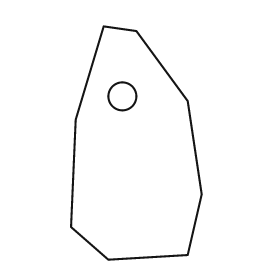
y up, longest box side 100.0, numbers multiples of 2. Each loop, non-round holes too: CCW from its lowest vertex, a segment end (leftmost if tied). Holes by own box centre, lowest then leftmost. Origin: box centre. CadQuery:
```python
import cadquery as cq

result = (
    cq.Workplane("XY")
    .moveTo(-12.0, -50.0)
    .lineTo(22.0, -48.0)
    .lineTo(28.0, -22.0)
    .lineTo(22.0, 18.0)
    .lineTo(0.0, 48.0)
    .lineTo(-14.0, 50.0)
    .lineTo(-26.0, 10.0)
    .lineTo(-28.0, -36.0)
    .close()
    .moveTo(-6.0, 20.0)
    .circle(6.0)
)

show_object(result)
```